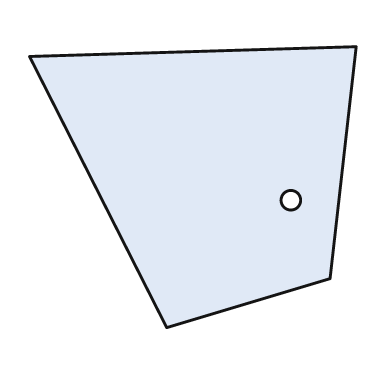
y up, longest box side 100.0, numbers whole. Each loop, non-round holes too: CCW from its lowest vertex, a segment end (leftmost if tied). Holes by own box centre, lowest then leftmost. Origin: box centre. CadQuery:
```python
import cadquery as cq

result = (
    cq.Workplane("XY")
    .moveTo(-8.0, -43.0)
    .lineTo(42.0, -28.0)
    .lineTo(50.0, 43.0)
    .lineTo(-50.0, 40.0)
    .close()
    .moveTo(30.0, -4.0)
    .circle(3.0)
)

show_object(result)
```